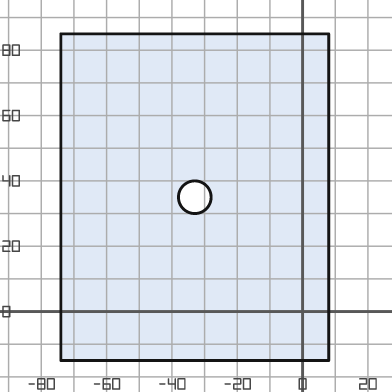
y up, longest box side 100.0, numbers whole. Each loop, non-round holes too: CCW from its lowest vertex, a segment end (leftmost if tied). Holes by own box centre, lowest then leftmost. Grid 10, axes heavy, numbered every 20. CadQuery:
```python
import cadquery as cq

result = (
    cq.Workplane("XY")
    .moveTo(-74.0, -15.0)
    .lineTo(8.0, -15.0)
    .lineTo(8.0, 85.0)
    .lineTo(-74.0, 85.0)
    .close()
    .moveTo(-33.0, 35.0)
    .circle(5.0)
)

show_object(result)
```